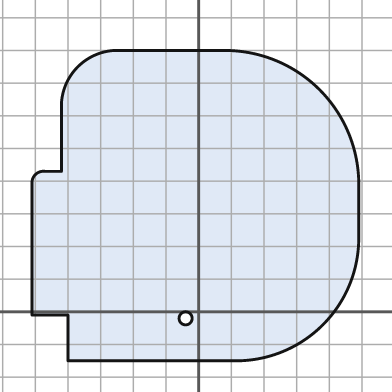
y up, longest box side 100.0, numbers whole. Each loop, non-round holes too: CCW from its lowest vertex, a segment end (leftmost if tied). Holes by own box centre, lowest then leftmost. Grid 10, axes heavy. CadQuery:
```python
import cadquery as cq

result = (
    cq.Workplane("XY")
    .moveTo(-40.0, -15.0)
    .lineTo(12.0, -15.0)
    .threePointArc((38.0, -4.0), (49.0, 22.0))
    .lineTo(49.0, 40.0)
    .threePointArc((37.0, 68.0), (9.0, 80.0))
    .lineTo(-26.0, 80.0)
    .threePointArc((-37.0, 75.0), (-42.0, 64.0))
    .lineTo(-42.0, 43.0)
    .lineTo(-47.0, 43.0)
    .threePointArc((-50.0, 42.0), (-51.0, 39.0))
    .lineTo(-51.0, -1.0)
    .lineTo(-40.0, -1.0)
    .close()
    .moveTo(-4.0, -2.0)
    .circle(2.0)
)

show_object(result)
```